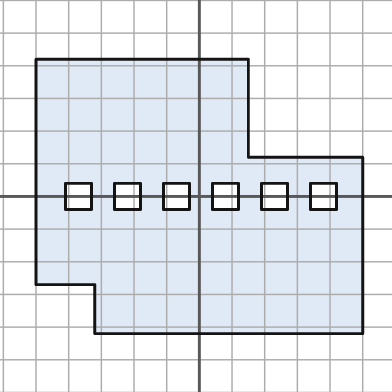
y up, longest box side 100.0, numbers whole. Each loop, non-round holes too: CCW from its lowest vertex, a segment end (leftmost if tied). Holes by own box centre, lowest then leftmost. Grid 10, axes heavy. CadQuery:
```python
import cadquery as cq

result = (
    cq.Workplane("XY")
    .moveTo(-32.0, -42.0)
    .lineTo(50.0, -42.0)
    .lineTo(50.0, 12.0)
    .lineTo(15.0, 12.0)
    .lineTo(15.0, 42.0)
    .lineTo(-50.0, 42.0)
    .lineTo(-50.0, -27.0)
    .lineTo(-32.0, -27.0)
    .close()
    .moveTo(-41.0, -4.0)
    .lineTo(-33.0, -4.0)
    .lineTo(-33.0, 4.0)
    .lineTo(-41.0, 4.0)
    .close()
    .moveTo(-26.0, -4.0)
    .lineTo(-18.0, -4.0)
    .lineTo(-18.0, 4.0)
    .lineTo(-26.0, 4.0)
    .close()
    .moveTo(-11.0, -4.0)
    .lineTo(-3.0, -4.0)
    .lineTo(-3.0, 4.0)
    .lineTo(-11.0, 4.0)
    .close()
    .moveTo(4.0, -4.0)
    .lineTo(12.0, -4.0)
    .lineTo(12.0, 4.0)
    .lineTo(4.0, 4.0)
    .close()
    .moveTo(19.0, -4.0)
    .lineTo(27.0, -4.0)
    .lineTo(27.0, 4.0)
    .lineTo(19.0, 4.0)
    .close()
    .moveTo(34.0, -4.0)
    .lineTo(42.0, -4.0)
    .lineTo(42.0, 4.0)
    .lineTo(34.0, 4.0)
    .close()
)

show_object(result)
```